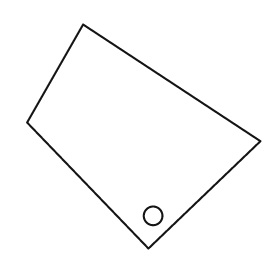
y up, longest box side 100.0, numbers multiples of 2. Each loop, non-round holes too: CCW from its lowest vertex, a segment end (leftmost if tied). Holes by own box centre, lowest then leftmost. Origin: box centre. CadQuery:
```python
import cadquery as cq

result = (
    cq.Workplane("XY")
    .moveTo(2.0, -48.0)
    .lineTo(50.0, -2.0)
    .lineTo(-26.0, 48.0)
    .lineTo(-50.0, 6.0)
    .close()
    .moveTo(4.0, -34.0)
    .circle(4.0)
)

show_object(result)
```